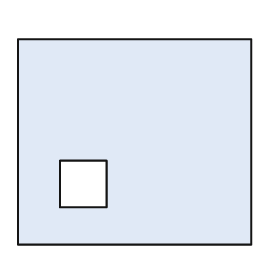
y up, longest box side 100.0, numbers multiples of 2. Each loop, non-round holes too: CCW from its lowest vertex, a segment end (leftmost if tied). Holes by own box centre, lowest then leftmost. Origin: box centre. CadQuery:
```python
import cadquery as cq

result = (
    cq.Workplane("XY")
    .moveTo(-50.0, -44.0)
    .lineTo(50.0, -44.0)
    .lineTo(50.0, 44.0)
    .lineTo(-50.0, 44.0)
    .close()
    .moveTo(-32.0, -28.0)
    .lineTo(-12.0, -28.0)
    .lineTo(-12.0, -8.0)
    .lineTo(-32.0, -8.0)
    .close()
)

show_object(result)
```